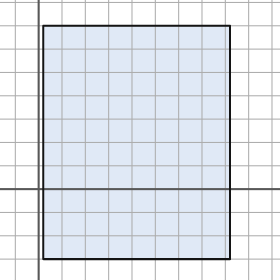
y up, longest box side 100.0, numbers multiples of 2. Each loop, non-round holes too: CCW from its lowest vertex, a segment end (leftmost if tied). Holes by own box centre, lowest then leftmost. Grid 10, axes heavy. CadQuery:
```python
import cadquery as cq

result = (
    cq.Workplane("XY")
    .moveTo(2.0, -30.0)
    .lineTo(82.0, -30.0)
    .lineTo(82.0, 70.0)
    .lineTo(2.0, 70.0)
    .close()
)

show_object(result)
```